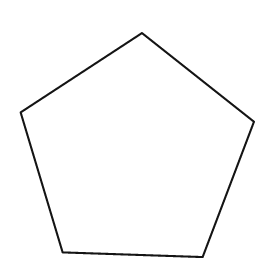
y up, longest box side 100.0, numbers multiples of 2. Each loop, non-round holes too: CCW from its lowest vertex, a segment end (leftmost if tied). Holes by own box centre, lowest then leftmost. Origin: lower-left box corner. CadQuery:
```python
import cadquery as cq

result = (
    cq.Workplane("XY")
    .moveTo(78.0, 0.0)
    .lineTo(100.0, 58.0)
    .lineTo(52.0, 96.0)
    .lineTo(0.0, 62.0)
    .lineTo(18.0, 2.0)
    .close()
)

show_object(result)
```